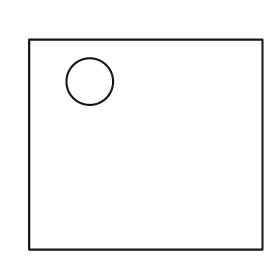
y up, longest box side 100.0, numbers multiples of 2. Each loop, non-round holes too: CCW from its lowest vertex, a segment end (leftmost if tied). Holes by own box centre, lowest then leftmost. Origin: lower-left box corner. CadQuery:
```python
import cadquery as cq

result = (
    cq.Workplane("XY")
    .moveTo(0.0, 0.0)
    .lineTo(100.0, 0.0)
    .lineTo(100.0, 90.0)
    .lineTo(0.0, 90.0)
    .close()
    .moveTo(26.0, 72.0)
    .circle(10.0)
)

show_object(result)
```